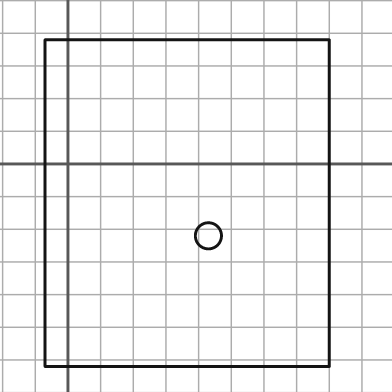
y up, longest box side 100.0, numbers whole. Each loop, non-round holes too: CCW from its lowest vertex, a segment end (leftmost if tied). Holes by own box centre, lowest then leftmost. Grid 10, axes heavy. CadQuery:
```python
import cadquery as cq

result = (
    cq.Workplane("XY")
    .moveTo(-7.0, -62.0)
    .lineTo(80.0, -62.0)
    .lineTo(80.0, 38.0)
    .lineTo(-7.0, 38.0)
    .close()
    .moveTo(43.0, -22.0)
    .circle(4.0)
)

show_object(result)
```